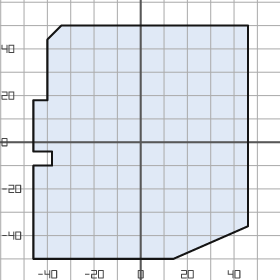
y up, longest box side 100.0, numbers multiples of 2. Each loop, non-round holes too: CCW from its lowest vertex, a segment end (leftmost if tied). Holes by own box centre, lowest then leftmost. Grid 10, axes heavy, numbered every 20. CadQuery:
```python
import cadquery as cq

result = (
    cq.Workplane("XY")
    .moveTo(-46.0, -50.0)
    .lineTo(14.0, -50.0)
    .lineTo(46.0, -36.0)
    .lineTo(46.0, 50.0)
    .lineTo(-34.0, 50.0)
    .lineTo(-40.0, 44.0)
    .lineTo(-40.0, 18.0)
    .lineTo(-46.0, 18.0)
    .lineTo(-46.0, -4.0)
    .lineTo(-38.0, -4.0)
    .lineTo(-38.0, -10.0)
    .lineTo(-46.0, -10.0)
    .close()
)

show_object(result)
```